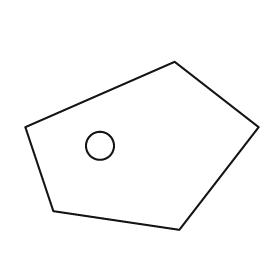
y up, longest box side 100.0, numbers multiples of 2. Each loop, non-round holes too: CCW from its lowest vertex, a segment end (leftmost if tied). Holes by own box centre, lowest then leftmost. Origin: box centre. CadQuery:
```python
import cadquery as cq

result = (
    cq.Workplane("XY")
    .moveTo(16.0, -36.0)
    .lineTo(50.0, 8.0)
    .lineTo(14.0, 36.0)
    .lineTo(-50.0, 8.0)
    .lineTo(-38.0, -28.0)
    .close()
    .moveTo(-18.0, 0.0)
    .circle(6.0)
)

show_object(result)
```